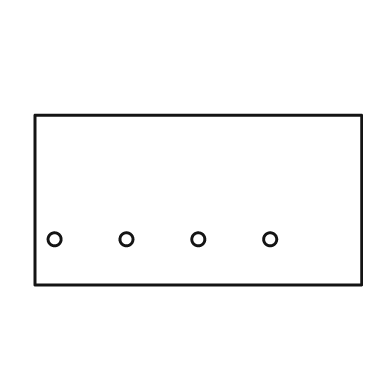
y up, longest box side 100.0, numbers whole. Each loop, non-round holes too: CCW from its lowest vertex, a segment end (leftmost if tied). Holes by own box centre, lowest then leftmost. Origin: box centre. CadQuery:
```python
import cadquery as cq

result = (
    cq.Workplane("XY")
    .moveTo(-50.0, -26.0)
    .lineTo(50.0, -26.0)
    .lineTo(50.0, 26.0)
    .lineTo(-50.0, 26.0)
    .close()
    .moveTo(-44.0, -12.0)
    .circle(2.0)
    .moveTo(-22.0, -12.0)
    .circle(2.0)
    .moveTo(0.0, -12.0)
    .circle(2.0)
    .moveTo(22.0, -12.0)
    .circle(2.0)
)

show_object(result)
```